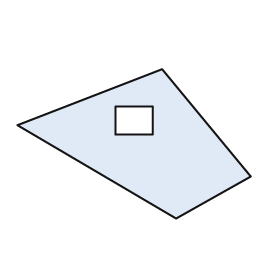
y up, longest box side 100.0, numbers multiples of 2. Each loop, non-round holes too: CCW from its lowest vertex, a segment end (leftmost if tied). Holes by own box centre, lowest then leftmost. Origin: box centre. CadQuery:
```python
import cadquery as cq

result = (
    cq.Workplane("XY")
    .moveTo(18.0, -32.0)
    .lineTo(50.0, -14.0)
    .lineTo(12.0, 32.0)
    .lineTo(-50.0, 8.0)
    .close()
    .moveTo(-8.0, 4.0)
    .lineTo(8.0, 4.0)
    .lineTo(8.0, 16.0)
    .lineTo(-8.0, 16.0)
    .close()
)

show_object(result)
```